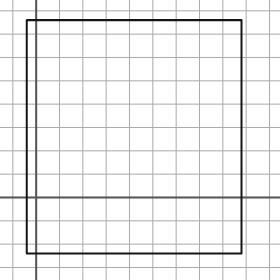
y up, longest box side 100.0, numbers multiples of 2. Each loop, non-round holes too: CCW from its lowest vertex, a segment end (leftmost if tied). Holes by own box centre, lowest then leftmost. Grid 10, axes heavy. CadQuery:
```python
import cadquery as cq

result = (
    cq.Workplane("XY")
    .moveTo(-4.0, -24.0)
    .lineTo(88.0, -24.0)
    .lineTo(88.0, 76.0)
    .lineTo(-4.0, 76.0)
    .close()
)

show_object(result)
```